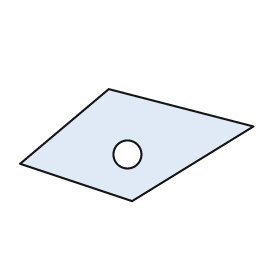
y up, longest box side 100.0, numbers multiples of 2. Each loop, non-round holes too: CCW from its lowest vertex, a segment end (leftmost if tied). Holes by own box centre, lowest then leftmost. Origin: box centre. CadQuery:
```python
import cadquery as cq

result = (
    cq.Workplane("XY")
    .moveTo(-2.0, -24.0)
    .lineTo(50.0, 8.0)
    .lineTo(-12.0, 24.0)
    .lineTo(-50.0, -8.0)
    .close()
    .moveTo(-4.0, -4.0)
    .circle(6.0)
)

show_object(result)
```